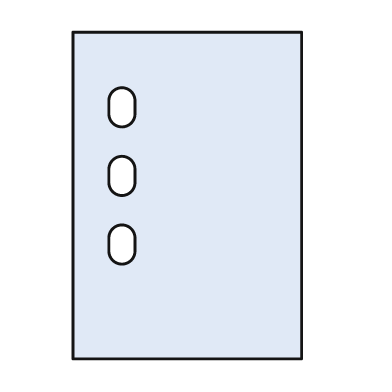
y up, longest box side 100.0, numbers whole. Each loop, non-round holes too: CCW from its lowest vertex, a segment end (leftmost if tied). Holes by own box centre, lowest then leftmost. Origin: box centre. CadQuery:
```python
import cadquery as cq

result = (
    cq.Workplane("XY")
    .moveTo(-35.0, -50.0)
    .lineTo(35.0, -50.0)
    .lineTo(35.0, 50.0)
    .lineTo(-35.0, 50.0)
    .close()
    .moveTo(-24.0, -17.0)
    .threePointArc((-20.0, -21.0), (-16.0, -17.0))
    .lineTo(-16.0, -13.0)
    .threePointArc((-20.0, -9.0), (-24.0, -13.0))
    .close()
    .moveTo(-24.0, 4.0)
    .threePointArc((-20.0, 0.0), (-16.0, 4.0))
    .lineTo(-16.0, 8.0)
    .threePointArc((-20.0, 12.0), (-24.0, 8.0))
    .close()
    .moveTo(-24.0, 25.0)
    .threePointArc((-20.0, 21.0), (-16.0, 25.0))
    .lineTo(-16.0, 29.0)
    .threePointArc((-20.0, 33.0), (-24.0, 29.0))
    .close()
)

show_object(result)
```